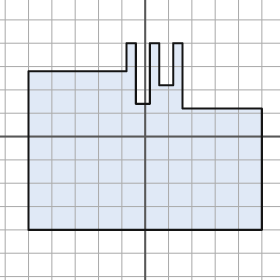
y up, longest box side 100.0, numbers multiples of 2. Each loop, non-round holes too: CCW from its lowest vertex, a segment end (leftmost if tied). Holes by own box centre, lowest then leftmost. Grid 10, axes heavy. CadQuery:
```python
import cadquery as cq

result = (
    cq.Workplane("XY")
    .moveTo(-50.0, -40.0)
    .lineTo(50.0, -40.0)
    .lineTo(50.0, 12.0)
    .lineTo(16.0, 12.0)
    .lineTo(16.0, 40.0)
    .lineTo(12.0, 40.0)
    .lineTo(12.0, 22.0)
    .lineTo(6.0, 22.0)
    .lineTo(6.0, 40.0)
    .lineTo(2.0, 40.0)
    .lineTo(2.0, 14.0)
    .lineTo(-4.0, 14.0)
    .lineTo(-4.0, 40.0)
    .lineTo(-8.0, 40.0)
    .lineTo(-8.0, 28.0)
    .lineTo(-50.0, 28.0)
    .close()
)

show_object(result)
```